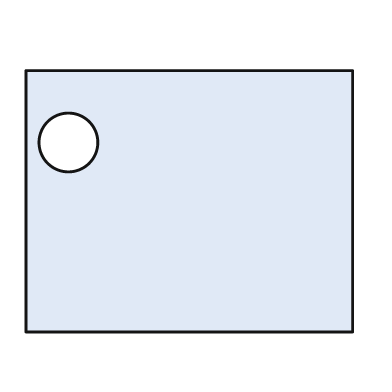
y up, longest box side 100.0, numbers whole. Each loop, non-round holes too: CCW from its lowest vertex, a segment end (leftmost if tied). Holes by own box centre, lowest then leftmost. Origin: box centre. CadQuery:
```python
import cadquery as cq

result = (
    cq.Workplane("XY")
    .moveTo(-50.0, -40.0)
    .lineTo(50.0, -40.0)
    .lineTo(50.0, 40.0)
    .lineTo(-50.0, 40.0)
    .close()
    .moveTo(-37.0, 18.0)
    .circle(9.0)
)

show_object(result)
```